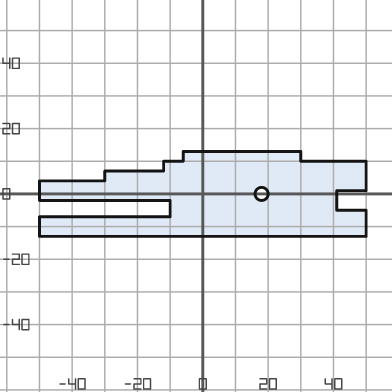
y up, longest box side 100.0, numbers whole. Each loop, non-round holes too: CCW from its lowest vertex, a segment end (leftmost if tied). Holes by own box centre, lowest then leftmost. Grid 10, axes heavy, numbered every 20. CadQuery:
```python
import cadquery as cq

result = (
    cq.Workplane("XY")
    .moveTo(-50.0, -13.0)
    .lineTo(50.0, -13.0)
    .lineTo(50.0, -5.0)
    .lineTo(41.0, -5.0)
    .lineTo(41.0, 1.0)
    .lineTo(50.0, 1.0)
    .lineTo(50.0, 10.0)
    .lineTo(30.0, 10.0)
    .lineTo(30.0, 13.0)
    .lineTo(-6.0, 13.0)
    .lineTo(-6.0, 10.0)
    .lineTo(-12.0, 10.0)
    .lineTo(-12.0, 7.0)
    .lineTo(-30.0, 7.0)
    .lineTo(-30.0, 4.0)
    .lineTo(-50.0, 4.0)
    .lineTo(-50.0, -2.0)
    .lineTo(-10.0, -2.0)
    .lineTo(-10.0, -7.0)
    .lineTo(-50.0, -7.0)
    .close()
    .moveTo(18.0, 0.0)
    .circle(2.0)
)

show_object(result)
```